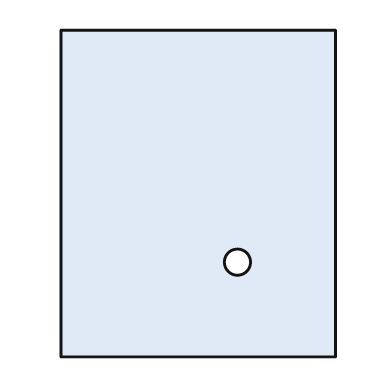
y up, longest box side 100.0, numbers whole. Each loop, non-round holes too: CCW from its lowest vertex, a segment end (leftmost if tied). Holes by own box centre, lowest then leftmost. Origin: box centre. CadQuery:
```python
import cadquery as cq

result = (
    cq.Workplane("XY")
    .moveTo(-42.0, -50.0)
    .lineTo(42.0, -50.0)
    .lineTo(42.0, 50.0)
    .lineTo(-42.0, 50.0)
    .close()
    .moveTo(12.0, -21.0)
    .circle(4.0)
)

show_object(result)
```